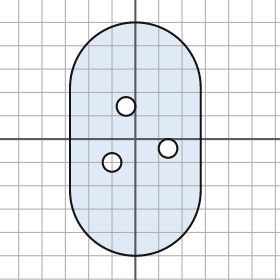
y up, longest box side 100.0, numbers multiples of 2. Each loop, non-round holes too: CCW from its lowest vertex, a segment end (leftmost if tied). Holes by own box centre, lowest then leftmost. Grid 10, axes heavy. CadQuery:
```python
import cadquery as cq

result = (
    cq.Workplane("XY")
    .moveTo(-28.0, -22.0)
    .threePointArc((0.0, -50.0), (28.0, -22.0))
    .lineTo(28.0, 22.0)
    .threePointArc((0.0, 50.0), (-28.0, 22.0))
    .close()
    .moveTo(-10.0, -10.0)
    .circle(4.0)
    .moveTo(14.0, -4.0)
    .circle(4.0)
    .moveTo(-4.0, 14.0)
    .circle(4.0)
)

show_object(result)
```